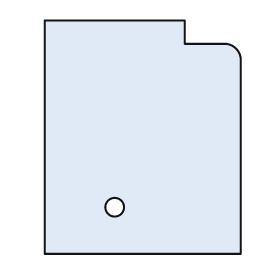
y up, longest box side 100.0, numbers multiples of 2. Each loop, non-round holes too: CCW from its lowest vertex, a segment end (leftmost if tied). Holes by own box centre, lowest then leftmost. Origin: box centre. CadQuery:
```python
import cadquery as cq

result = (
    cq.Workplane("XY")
    .moveTo(-42.0, -50.0)
    .lineTo(42.0, -50.0)
    .lineTo(42.0, 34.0)
    .threePointArc((40.0, 38.0), (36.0, 40.0))
    .lineTo(18.0, 40.0)
    .lineTo(18.0, 50.0)
    .lineTo(-42.0, 50.0)
    .close()
    .moveTo(-12.0, -30.0)
    .circle(4.0)
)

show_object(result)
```